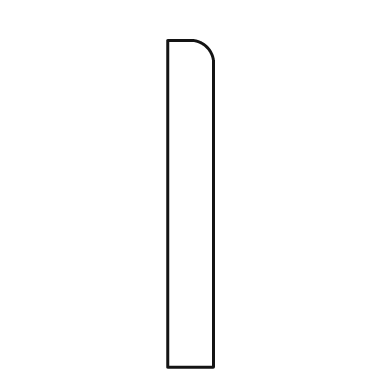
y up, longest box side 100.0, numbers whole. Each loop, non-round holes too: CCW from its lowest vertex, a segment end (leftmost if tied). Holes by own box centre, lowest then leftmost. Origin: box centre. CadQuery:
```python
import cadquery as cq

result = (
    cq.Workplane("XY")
    .moveTo(-7.0, -50.0)
    .lineTo(7.0, -50.0)
    .lineTo(7.0, 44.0)
    .threePointArc((5.0, 48.0), (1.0, 50.0))
    .lineTo(-7.0, 50.0)
    .close()
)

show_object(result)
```